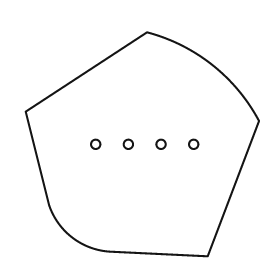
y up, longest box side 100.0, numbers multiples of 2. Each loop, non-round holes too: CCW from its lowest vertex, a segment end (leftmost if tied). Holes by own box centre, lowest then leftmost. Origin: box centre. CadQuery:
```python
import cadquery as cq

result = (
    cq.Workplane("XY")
    .moveTo(28.0, -48.0)
    .lineTo(50.0, 10.0)
    .threePointArc((30.0, 34.0), (2.0, 48.0))
    .lineTo(-50.0, 14.0)
    .lineTo(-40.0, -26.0)
    .threePointArc((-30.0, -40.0), (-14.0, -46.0))
    .close()
    .moveTo(-20.0, 0.0)
    .circle(2.0)
    .moveTo(-6.0, 0.0)
    .circle(2.0)
    .moveTo(8.0, 0.0)
    .circle(2.0)
    .moveTo(22.0, 0.0)
    .circle(2.0)
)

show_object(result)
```